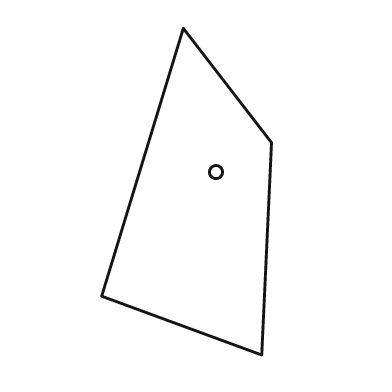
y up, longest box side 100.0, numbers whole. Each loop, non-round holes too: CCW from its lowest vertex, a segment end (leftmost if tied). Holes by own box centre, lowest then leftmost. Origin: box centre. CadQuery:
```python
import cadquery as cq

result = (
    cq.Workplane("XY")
    .moveTo(23.0, -50.0)
    .lineTo(26.0, 15.0)
    .lineTo(-1.0, 50.0)
    .lineTo(-26.0, -32.0)
    .close()
    .moveTo(9.0, 6.0)
    .circle(2.0)
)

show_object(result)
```